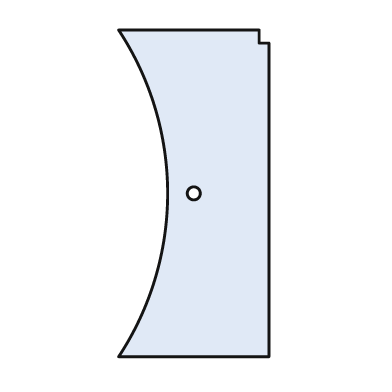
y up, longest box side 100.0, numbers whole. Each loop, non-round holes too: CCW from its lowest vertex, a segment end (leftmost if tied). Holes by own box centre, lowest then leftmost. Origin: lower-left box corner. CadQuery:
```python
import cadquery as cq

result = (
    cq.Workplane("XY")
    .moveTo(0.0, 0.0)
    .lineTo(46.0, 0.0)
    .lineTo(46.0, 96.0)
    .lineTo(43.0, 96.0)
    .lineTo(43.0, 100.0)
    .lineTo(0.0, 100.0)
    .threePointArc((15.0, 50.0), (0.0, 0.0))
    .close()
    .moveTo(23.0, 50.0)
    .circle(2.0)
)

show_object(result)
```